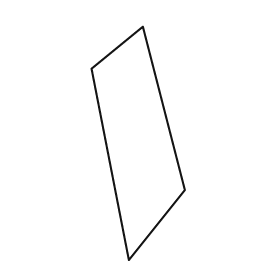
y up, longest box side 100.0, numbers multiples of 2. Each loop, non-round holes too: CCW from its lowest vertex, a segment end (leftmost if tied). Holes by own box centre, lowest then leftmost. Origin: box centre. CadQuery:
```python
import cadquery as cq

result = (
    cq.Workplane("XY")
    .moveTo(-4.0, -50.0)
    .lineTo(20.0, -20.0)
    .lineTo(2.0, 50.0)
    .lineTo(-20.0, 32.0)
    .close()
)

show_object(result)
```